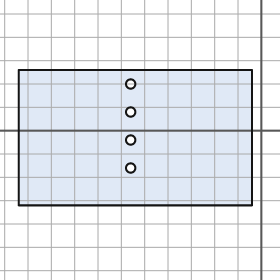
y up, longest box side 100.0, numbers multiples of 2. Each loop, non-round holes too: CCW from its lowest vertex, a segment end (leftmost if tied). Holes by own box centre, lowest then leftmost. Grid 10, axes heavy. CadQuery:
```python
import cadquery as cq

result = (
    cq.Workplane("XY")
    .moveTo(-104.0, -32.0)
    .lineTo(-4.0, -32.0)
    .lineTo(-4.0, 26.0)
    .lineTo(-104.0, 26.0)
    .close()
    .moveTo(-56.0, -16.0)
    .circle(2.0)
    .moveTo(-56.0, -4.0)
    .circle(2.0)
    .moveTo(-56.0, 8.0)
    .circle(2.0)
    .moveTo(-56.0, 20.0)
    .circle(2.0)
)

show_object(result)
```